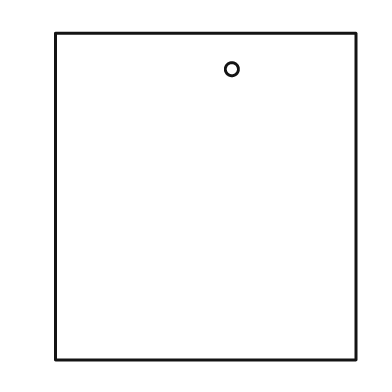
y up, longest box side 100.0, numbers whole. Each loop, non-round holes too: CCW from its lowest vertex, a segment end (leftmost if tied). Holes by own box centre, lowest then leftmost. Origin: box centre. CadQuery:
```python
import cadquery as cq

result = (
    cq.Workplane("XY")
    .moveTo(-46.0, -50.0)
    .lineTo(46.0, -50.0)
    .lineTo(46.0, 50.0)
    .lineTo(-46.0, 50.0)
    .close()
    .moveTo(8.0, 39.0)
    .circle(2.0)
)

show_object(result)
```